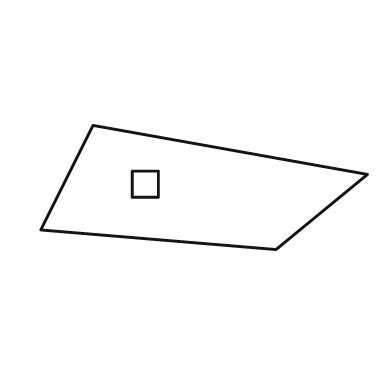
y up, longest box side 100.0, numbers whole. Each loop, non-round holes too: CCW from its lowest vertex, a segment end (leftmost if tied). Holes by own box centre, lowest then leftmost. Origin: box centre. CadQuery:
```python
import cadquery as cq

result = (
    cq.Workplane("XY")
    .moveTo(22.0, -19.0)
    .lineTo(50.0, 4.0)
    .lineTo(-34.0, 19.0)
    .lineTo(-50.0, -13.0)
    .close()
    .moveTo(-22.0, -3.0)
    .lineTo(-14.0, -3.0)
    .lineTo(-14.0, 5.0)
    .lineTo(-22.0, 5.0)
    .close()
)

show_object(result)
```